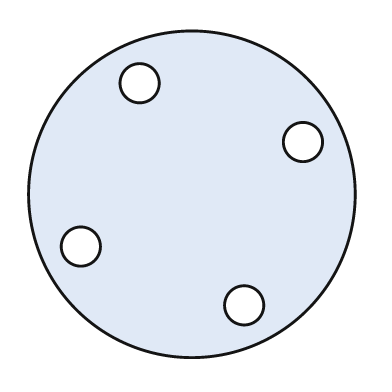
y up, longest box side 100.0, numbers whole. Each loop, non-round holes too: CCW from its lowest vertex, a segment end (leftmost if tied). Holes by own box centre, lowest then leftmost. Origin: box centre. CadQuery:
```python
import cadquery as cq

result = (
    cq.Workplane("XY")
    .moveTo(0.0, 0.0)
    .circle(50.0)
    .moveTo(16.0, -34.0)
    .circle(6.0)
    .moveTo(-34.0, -16.0)
    .circle(6.0)
    .moveTo(34.0, 16.0)
    .circle(6.0)
    .moveTo(-16.0, 34.0)
    .circle(6.0)
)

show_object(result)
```